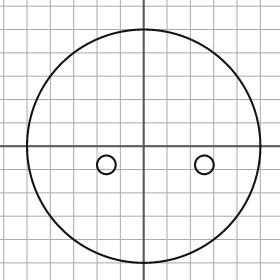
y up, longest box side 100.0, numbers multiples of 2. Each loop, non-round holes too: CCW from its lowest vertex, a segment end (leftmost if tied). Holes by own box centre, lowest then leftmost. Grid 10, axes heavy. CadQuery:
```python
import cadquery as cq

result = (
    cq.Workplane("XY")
    .moveTo(0.0, 0.0)
    .circle(50.0)
    .moveTo(-16.0, -8.0)
    .circle(4.0)
    .moveTo(26.0, -8.0)
    .circle(4.0)
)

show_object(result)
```